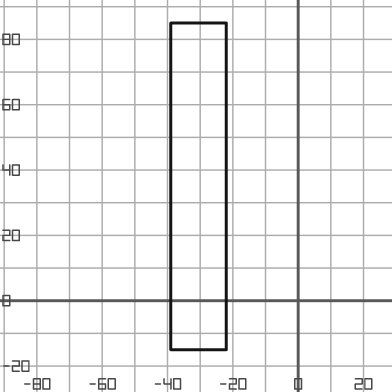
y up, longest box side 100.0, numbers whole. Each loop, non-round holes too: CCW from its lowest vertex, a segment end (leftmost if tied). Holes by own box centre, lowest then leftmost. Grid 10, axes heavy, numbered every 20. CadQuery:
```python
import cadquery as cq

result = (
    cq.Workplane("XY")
    .moveTo(-39.0, -15.0)
    .lineTo(-22.0, -15.0)
    .lineTo(-22.0, 85.0)
    .lineTo(-39.0, 85.0)
    .close()
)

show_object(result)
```